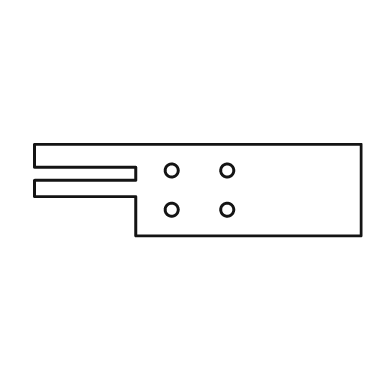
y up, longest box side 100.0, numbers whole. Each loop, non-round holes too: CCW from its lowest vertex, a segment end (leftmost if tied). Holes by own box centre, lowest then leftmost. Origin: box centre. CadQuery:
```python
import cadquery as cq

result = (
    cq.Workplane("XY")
    .moveTo(-19.0, -14.0)
    .lineTo(50.0, -14.0)
    .lineTo(50.0, 14.0)
    .lineTo(-50.0, 14.0)
    .lineTo(-50.0, 7.0)
    .lineTo(-19.0, 7.0)
    .lineTo(-19.0, 3.0)
    .lineTo(-50.0, 3.0)
    .lineTo(-50.0, -2.0)
    .lineTo(-19.0, -2.0)
    .close()
    .moveTo(-8.0, -6.0)
    .circle(2.0)
    .moveTo(9.0, -6.0)
    .circle(2.0)
    .moveTo(-8.0, 6.0)
    .circle(2.0)
    .moveTo(9.0, 6.0)
    .circle(2.0)
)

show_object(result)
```